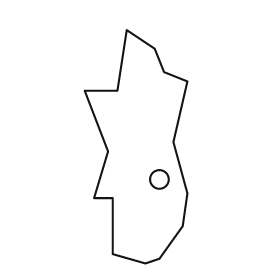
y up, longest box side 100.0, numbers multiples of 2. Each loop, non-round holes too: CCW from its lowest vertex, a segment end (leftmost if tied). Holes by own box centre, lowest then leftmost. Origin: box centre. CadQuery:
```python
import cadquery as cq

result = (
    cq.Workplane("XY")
    .moveTo(4.0, -50.0)
    .lineTo(10.0, -48.0)
    .lineTo(20.0, -34.0)
    .lineTo(22.0, -20.0)
    .lineTo(16.0, 2.0)
    .lineTo(22.0, 28.0)
    .lineTo(12.0, 32.0)
    .lineTo(8.0, 42.0)
    .lineTo(-4.0, 50.0)
    .lineTo(-8.0, 24.0)
    .lineTo(-22.0, 24.0)
    .lineTo(-12.0, -2.0)
    .lineTo(-18.0, -22.0)
    .lineTo(-10.0, -22.0)
    .lineTo(-10.0, -46.0)
    .close()
    .moveTo(10.0, -14.0)
    .circle(4.0)
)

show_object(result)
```